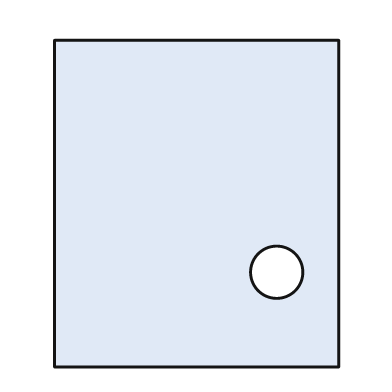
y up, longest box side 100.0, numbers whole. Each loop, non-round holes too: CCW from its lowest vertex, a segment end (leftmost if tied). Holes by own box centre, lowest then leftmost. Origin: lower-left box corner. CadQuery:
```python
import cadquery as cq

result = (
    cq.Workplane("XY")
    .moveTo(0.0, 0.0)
    .lineTo(87.0, 0.0)
    .lineTo(87.0, 100.0)
    .lineTo(0.0, 100.0)
    .close()
    .moveTo(68.0, 29.0)
    .circle(8.0)
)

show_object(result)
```